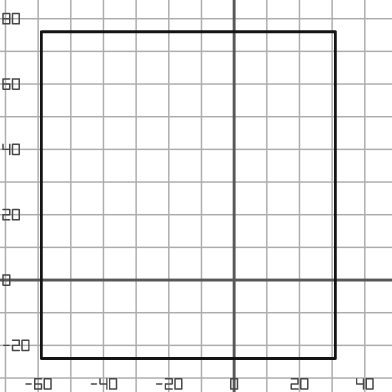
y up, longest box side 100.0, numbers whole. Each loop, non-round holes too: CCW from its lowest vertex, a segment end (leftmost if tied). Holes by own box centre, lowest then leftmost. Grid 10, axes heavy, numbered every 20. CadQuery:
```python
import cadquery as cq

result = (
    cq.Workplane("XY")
    .moveTo(-59.0, -24.0)
    .lineTo(31.0, -24.0)
    .lineTo(31.0, 76.0)
    .lineTo(-59.0, 76.0)
    .close()
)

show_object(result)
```